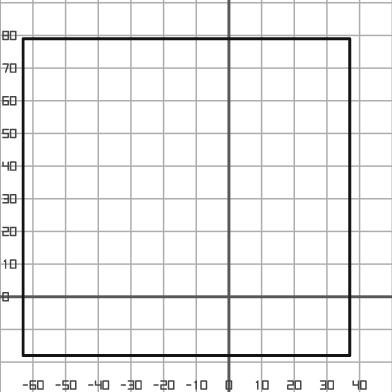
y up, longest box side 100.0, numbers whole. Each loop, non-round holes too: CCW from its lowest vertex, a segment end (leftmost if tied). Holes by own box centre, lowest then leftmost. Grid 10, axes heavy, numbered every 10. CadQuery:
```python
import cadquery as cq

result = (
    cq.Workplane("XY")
    .moveTo(-63.0, -18.0)
    .lineTo(37.0, -18.0)
    .lineTo(37.0, 79.0)
    .lineTo(-63.0, 79.0)
    .close()
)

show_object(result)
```